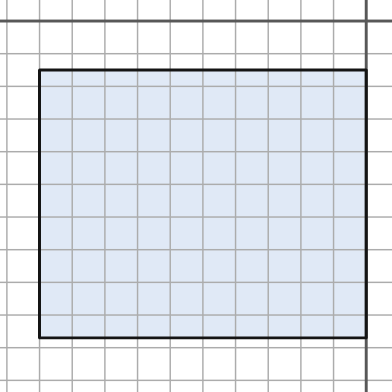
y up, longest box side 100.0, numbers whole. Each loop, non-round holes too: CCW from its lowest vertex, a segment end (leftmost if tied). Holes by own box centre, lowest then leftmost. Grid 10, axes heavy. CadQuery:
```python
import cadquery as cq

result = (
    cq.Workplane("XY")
    .moveTo(-100.0, -97.0)
    .lineTo(0.0, -97.0)
    .lineTo(0.0, -15.0)
    .lineTo(-100.0, -15.0)
    .close()
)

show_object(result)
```